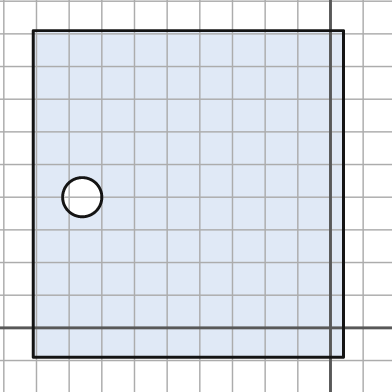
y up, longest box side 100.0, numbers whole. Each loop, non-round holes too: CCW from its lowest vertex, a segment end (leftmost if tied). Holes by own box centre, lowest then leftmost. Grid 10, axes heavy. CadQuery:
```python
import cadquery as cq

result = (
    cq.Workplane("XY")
    .moveTo(-91.0, -9.0)
    .lineTo(4.0, -9.0)
    .lineTo(4.0, 91.0)
    .lineTo(-91.0, 91.0)
    .close()
    .moveTo(-76.0, 40.0)
    .circle(6.0)
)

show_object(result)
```